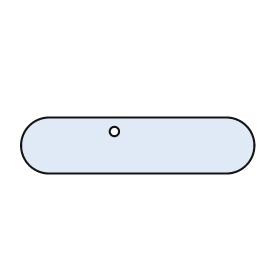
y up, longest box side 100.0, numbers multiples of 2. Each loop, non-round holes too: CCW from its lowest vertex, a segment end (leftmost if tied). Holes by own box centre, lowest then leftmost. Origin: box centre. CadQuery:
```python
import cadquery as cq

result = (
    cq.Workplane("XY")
    .moveTo(-38.0, -12.0)
    .lineTo(38.0, -12.0)
    .threePointArc((50.0, 0.0), (38.0, 12.0))
    .lineTo(-38.0, 12.0)
    .threePointArc((-50.0, 0.0), (-38.0, -12.0))
    .close()
    .moveTo(-10.0, 6.0)
    .circle(2.0)
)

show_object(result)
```